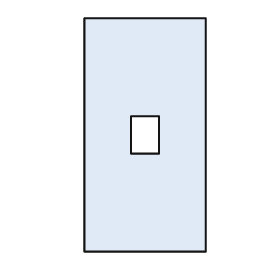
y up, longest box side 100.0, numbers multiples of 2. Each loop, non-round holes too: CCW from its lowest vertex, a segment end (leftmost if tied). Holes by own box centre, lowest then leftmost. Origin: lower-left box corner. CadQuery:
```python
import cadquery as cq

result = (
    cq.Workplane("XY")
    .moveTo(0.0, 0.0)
    .lineTo(52.0, 0.0)
    .lineTo(52.0, 100.0)
    .lineTo(0.0, 100.0)
    .close()
    .moveTo(20.0, 42.0)
    .lineTo(32.0, 42.0)
    .lineTo(32.0, 58.0)
    .lineTo(20.0, 58.0)
    .close()
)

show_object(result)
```